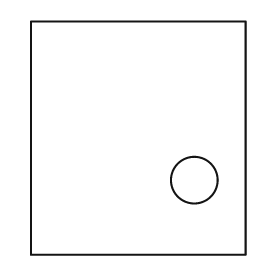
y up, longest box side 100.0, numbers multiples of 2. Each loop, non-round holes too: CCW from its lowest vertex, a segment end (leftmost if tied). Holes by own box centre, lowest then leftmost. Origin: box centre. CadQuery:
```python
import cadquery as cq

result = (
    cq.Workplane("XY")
    .moveTo(-46.0, -50.0)
    .lineTo(46.0, -50.0)
    .lineTo(46.0, 50.0)
    .lineTo(-46.0, 50.0)
    .close()
    .moveTo(24.0, -18.0)
    .circle(10.0)
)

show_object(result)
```